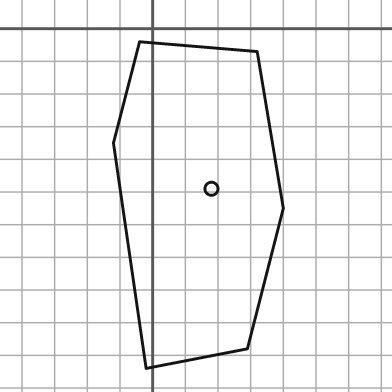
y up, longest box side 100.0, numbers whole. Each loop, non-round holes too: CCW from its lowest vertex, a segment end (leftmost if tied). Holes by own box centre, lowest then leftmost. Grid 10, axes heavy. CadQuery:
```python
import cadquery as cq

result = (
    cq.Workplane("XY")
    .moveTo(-2.0, -104.0)
    .lineTo(29.0, -98.0)
    .lineTo(40.0, -55.0)
    .lineTo(32.0, -7.0)
    .lineTo(-4.0, -4.0)
    .lineTo(-12.0, -35.0)
    .close()
    .moveTo(18.0, -49.0)
    .circle(2.0)
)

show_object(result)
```